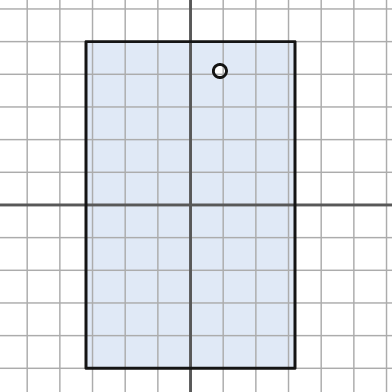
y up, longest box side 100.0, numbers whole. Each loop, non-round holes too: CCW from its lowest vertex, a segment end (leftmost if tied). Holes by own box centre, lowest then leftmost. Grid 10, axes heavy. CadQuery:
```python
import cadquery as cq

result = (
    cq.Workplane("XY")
    .moveTo(-32.0, -50.0)
    .lineTo(32.0, -50.0)
    .lineTo(32.0, 50.0)
    .lineTo(-32.0, 50.0)
    .close()
    .moveTo(9.0, 41.0)
    .circle(2.0)
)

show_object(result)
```